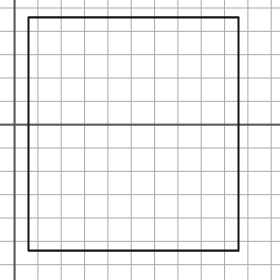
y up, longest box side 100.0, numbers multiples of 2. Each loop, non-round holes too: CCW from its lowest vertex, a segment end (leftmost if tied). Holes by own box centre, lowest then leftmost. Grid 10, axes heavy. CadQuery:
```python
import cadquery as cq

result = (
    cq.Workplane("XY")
    .moveTo(6.0, -54.0)
    .lineTo(96.0, -54.0)
    .lineTo(96.0, 46.0)
    .lineTo(6.0, 46.0)
    .close()
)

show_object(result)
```